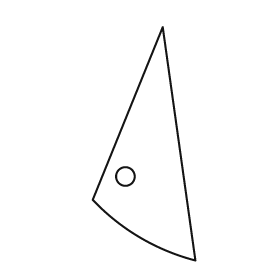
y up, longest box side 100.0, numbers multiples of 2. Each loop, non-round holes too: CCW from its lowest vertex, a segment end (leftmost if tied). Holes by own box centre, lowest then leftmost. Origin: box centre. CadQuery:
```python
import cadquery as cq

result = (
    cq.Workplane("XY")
    .moveTo(22.0, -50.0)
    .lineTo(8.0, 50.0)
    .lineTo(-22.0, -24.0)
    .threePointArc((-2.0, -40.0), (22.0, -50.0))
    .close()
    .moveTo(-8.0, -14.0)
    .circle(4.0)
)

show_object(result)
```